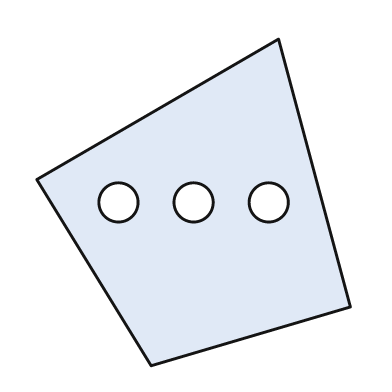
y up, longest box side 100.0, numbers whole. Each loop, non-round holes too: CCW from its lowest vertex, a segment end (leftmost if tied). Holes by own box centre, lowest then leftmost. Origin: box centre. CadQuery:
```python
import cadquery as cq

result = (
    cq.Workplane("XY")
    .moveTo(-13.0, -50.0)
    .lineTo(48.0, -32.0)
    .lineTo(26.0, 50.0)
    .lineTo(-48.0, 7.0)
    .close()
    .moveTo(-23.0, 0.0)
    .circle(6.0)
    .moveTo(0.0, 0.0)
    .circle(6.0)
    .moveTo(23.0, 0.0)
    .circle(6.0)
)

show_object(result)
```